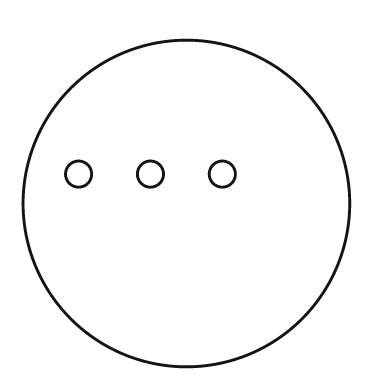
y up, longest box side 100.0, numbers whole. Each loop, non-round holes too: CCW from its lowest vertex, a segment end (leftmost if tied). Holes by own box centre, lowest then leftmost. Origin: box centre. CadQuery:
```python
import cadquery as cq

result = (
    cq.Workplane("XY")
    .moveTo(0.0, 0.0)
    .circle(50.0)
    .moveTo(-33.0, 9.0)
    .circle(4.0)
    .moveTo(-11.0, 9.0)
    .circle(4.0)
    .moveTo(11.0, 9.0)
    .circle(4.0)
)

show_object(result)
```